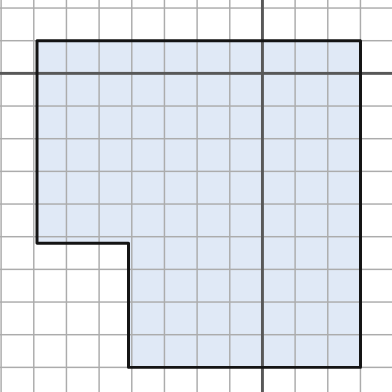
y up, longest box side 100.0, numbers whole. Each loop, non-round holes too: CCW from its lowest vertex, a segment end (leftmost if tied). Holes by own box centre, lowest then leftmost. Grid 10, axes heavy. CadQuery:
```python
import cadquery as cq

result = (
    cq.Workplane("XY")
    .moveTo(-41.0, -90.0)
    .lineTo(30.0, -90.0)
    .lineTo(30.0, 10.0)
    .lineTo(-69.0, 10.0)
    .lineTo(-69.0, -52.0)
    .lineTo(-41.0, -52.0)
    .close()
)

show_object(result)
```